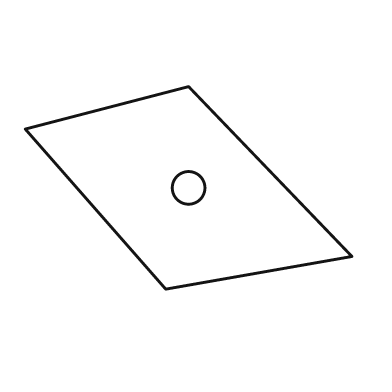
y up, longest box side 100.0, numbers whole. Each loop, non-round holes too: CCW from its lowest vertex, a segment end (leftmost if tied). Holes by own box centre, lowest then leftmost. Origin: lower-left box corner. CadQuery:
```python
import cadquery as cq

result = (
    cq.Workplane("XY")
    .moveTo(43.0, 0.0)
    .lineTo(100.0, 10.0)
    .lineTo(50.0, 62.0)
    .lineTo(0.0, 49.0)
    .close()
    .moveTo(50.0, 31.0)
    .circle(5.0)
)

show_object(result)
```